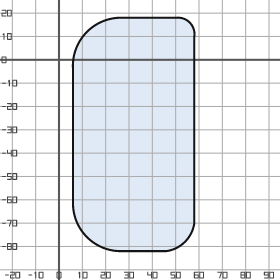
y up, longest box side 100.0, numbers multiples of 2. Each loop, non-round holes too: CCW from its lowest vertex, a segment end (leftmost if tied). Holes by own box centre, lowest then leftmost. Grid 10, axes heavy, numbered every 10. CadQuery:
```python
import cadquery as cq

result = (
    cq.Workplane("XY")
    .moveTo(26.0, -82.0)
    .lineTo(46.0, -82.0)
    .threePointArc((54.0, -78.0), (58.0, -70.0))
    .lineTo(58.0, 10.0)
    .threePointArc((56.0, 16.0), (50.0, 18.0))
    .lineTo(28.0, 18.0)
    .threePointArc((12.0, 12.0), (6.0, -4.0))
    .lineTo(6.0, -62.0)
    .threePointArc((12.0, -76.0), (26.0, -82.0))
    .close()
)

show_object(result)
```